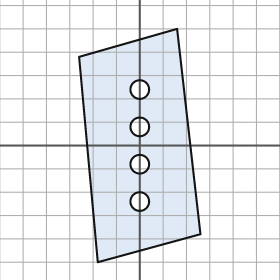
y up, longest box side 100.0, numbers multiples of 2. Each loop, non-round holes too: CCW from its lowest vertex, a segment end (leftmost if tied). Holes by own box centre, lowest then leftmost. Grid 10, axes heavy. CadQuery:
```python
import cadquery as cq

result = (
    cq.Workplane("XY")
    .moveTo(-18.0, -50.0)
    .lineTo(26.0, -38.0)
    .lineTo(16.0, 50.0)
    .lineTo(-26.0, 38.0)
    .close()
    .moveTo(0.0, -24.0)
    .circle(4.0)
    .moveTo(0.0, -8.0)
    .circle(4.0)
    .moveTo(0.0, 8.0)
    .circle(4.0)
    .moveTo(0.0, 24.0)
    .circle(4.0)
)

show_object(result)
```